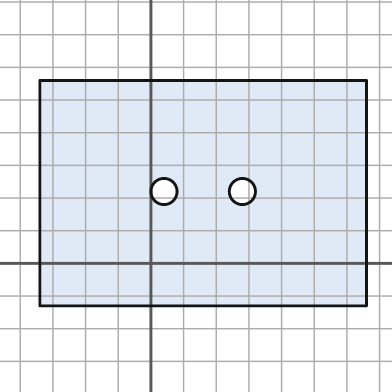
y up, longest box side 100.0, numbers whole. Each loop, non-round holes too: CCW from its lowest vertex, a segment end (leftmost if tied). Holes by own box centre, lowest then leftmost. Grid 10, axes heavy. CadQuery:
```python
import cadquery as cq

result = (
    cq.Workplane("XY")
    .moveTo(-34.0, -13.0)
    .lineTo(66.0, -13.0)
    .lineTo(66.0, 56.0)
    .lineTo(-34.0, 56.0)
    .close()
    .moveTo(4.0, 22.0)
    .circle(4.0)
    .moveTo(28.0, 22.0)
    .circle(4.0)
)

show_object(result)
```